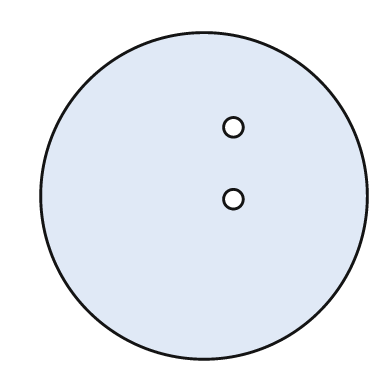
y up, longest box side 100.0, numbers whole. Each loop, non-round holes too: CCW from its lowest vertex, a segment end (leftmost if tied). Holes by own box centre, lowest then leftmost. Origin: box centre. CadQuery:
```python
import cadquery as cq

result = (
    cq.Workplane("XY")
    .moveTo(0.0, 0.0)
    .circle(50.0)
    .moveTo(9.0, -1.0)
    .circle(3.0)
    .moveTo(9.0, 21.0)
    .circle(3.0)
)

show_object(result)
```